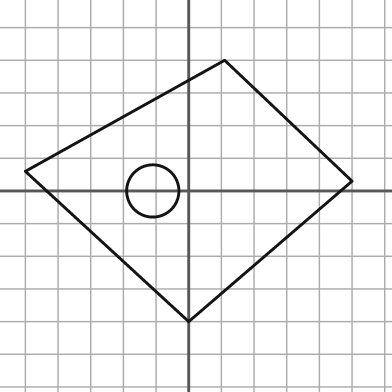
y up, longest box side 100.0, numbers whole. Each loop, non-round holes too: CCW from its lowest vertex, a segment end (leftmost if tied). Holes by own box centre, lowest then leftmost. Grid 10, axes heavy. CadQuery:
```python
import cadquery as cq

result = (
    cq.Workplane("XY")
    .moveTo(0.0, -40.0)
    .lineTo(50.0, 3.0)
    .lineTo(11.0, 40.0)
    .lineTo(-50.0, 6.0)
    .close()
    .moveTo(-11.0, 0.0)
    .circle(8.0)
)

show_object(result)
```